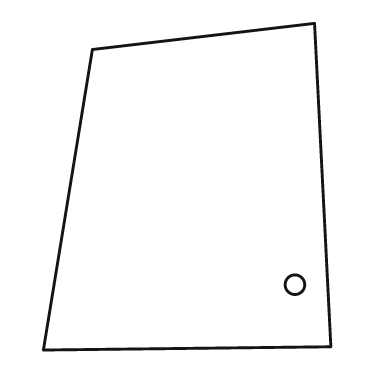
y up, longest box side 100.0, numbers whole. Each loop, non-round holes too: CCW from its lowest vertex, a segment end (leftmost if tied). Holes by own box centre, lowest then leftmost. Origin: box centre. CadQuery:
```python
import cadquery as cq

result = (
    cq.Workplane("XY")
    .moveTo(-44.0, -50.0)
    .lineTo(44.0, -49.0)
    .lineTo(39.0, 50.0)
    .lineTo(-29.0, 42.0)
    .close()
    .moveTo(33.0, -30.0)
    .circle(3.0)
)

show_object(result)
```